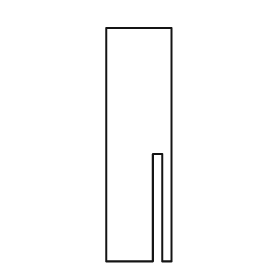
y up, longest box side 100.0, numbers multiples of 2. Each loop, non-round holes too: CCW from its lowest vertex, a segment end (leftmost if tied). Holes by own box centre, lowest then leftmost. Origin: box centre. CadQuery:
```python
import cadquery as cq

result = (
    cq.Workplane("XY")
    .moveTo(-14.0, -50.0)
    .lineTo(6.0, -50.0)
    .lineTo(6.0, -4.0)
    .lineTo(10.0, -4.0)
    .lineTo(10.0, -50.0)
    .lineTo(14.0, -50.0)
    .lineTo(14.0, 50.0)
    .lineTo(-14.0, 50.0)
    .close()
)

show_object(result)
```